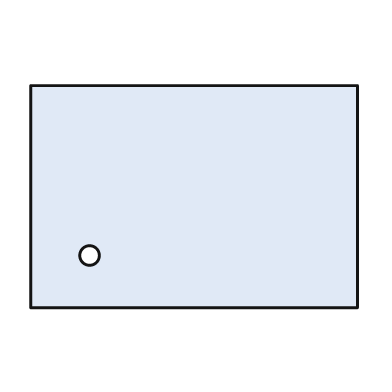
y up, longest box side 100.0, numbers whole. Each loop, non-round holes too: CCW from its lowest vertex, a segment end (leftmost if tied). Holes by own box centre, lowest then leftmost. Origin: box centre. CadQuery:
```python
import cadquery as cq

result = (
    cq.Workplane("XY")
    .moveTo(-50.0, -34.0)
    .lineTo(50.0, -34.0)
    .lineTo(50.0, 34.0)
    .lineTo(-50.0, 34.0)
    .close()
    .moveTo(-32.0, -18.0)
    .circle(3.0)
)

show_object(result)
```